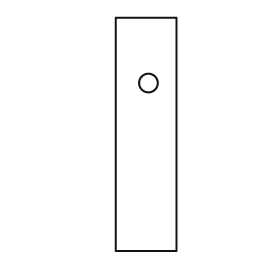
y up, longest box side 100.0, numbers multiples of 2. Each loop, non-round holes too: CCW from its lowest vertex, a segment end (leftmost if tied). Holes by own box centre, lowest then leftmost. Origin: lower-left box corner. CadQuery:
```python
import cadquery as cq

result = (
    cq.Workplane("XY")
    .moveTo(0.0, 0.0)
    .lineTo(26.0, 0.0)
    .lineTo(26.0, 100.0)
    .lineTo(0.0, 100.0)
    .close()
    .moveTo(14.0, 72.0)
    .circle(4.0)
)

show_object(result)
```